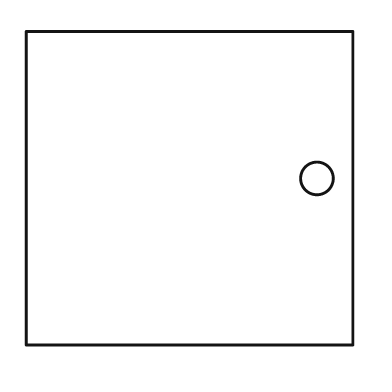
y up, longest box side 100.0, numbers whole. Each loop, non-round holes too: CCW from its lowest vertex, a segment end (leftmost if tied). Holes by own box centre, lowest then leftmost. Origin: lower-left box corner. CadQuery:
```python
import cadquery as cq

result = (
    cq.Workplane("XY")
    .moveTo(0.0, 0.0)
    .lineTo(100.0, 0.0)
    .lineTo(100.0, 96.0)
    .lineTo(0.0, 96.0)
    .close()
    .moveTo(89.0, 51.0)
    .circle(5.0)
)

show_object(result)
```